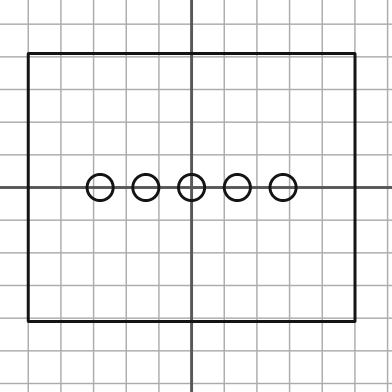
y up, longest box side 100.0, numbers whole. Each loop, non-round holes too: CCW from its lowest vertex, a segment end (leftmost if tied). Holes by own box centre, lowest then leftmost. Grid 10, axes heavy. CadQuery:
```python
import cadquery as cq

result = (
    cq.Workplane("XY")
    .moveTo(-50.0, -41.0)
    .lineTo(50.0, -41.0)
    .lineTo(50.0, 41.0)
    .lineTo(-50.0, 41.0)
    .close()
    .moveTo(-28.0, 0.0)
    .circle(4.0)
    .moveTo(-14.0, 0.0)
    .circle(4.0)
    .moveTo(0.0, 0.0)
    .circle(4.0)
    .moveTo(14.0, 0.0)
    .circle(4.0)
    .moveTo(28.0, 0.0)
    .circle(4.0)
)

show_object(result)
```